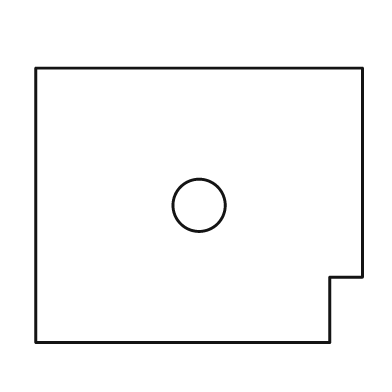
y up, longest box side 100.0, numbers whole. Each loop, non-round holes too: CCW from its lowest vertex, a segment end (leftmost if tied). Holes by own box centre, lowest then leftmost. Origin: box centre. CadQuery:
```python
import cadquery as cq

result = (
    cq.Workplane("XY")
    .moveTo(-50.0, -42.0)
    .lineTo(40.0, -42.0)
    .lineTo(40.0, -22.0)
    .lineTo(50.0, -22.0)
    .lineTo(50.0, 42.0)
    .lineTo(-50.0, 42.0)
    .close()
    .moveTo(0.0, 0.0)
    .circle(8.0)
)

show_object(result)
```